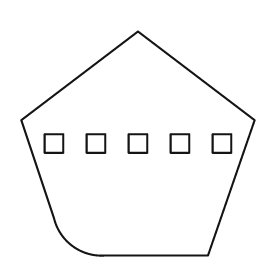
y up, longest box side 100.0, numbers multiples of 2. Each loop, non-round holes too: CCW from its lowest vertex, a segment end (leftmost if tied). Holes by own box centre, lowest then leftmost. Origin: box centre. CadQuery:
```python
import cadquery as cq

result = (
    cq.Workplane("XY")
    .moveTo(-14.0, -48.0)
    .lineTo(30.0, -48.0)
    .lineTo(50.0, 10.0)
    .lineTo(0.0, 48.0)
    .lineTo(-50.0, 10.0)
    .lineTo(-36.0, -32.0)
    .threePointArc((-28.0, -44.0), (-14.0, -48.0))
    .close()
    .moveTo(-40.0, -4.0)
    .lineTo(-32.0, -4.0)
    .lineTo(-32.0, 4.0)
    .lineTo(-40.0, 4.0)
    .close()
    .moveTo(-22.0, -4.0)
    .lineTo(-14.0, -4.0)
    .lineTo(-14.0, 4.0)
    .lineTo(-22.0, 4.0)
    .close()
    .moveTo(-4.0, -4.0)
    .lineTo(4.0, -4.0)
    .lineTo(4.0, 4.0)
    .lineTo(-4.0, 4.0)
    .close()
    .moveTo(14.0, -4.0)
    .lineTo(22.0, -4.0)
    .lineTo(22.0, 4.0)
    .lineTo(14.0, 4.0)
    .close()
    .moveTo(32.0, -4.0)
    .lineTo(40.0, -4.0)
    .lineTo(40.0, 4.0)
    .lineTo(32.0, 4.0)
    .close()
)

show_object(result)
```